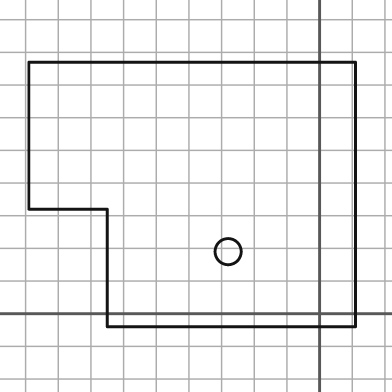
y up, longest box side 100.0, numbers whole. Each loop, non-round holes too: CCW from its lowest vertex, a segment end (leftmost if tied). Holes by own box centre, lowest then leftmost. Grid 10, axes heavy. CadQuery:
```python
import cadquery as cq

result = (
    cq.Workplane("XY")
    .moveTo(-65.0, -4.0)
    .lineTo(11.0, -4.0)
    .lineTo(11.0, 77.0)
    .lineTo(-89.0, 77.0)
    .lineTo(-89.0, 32.0)
    .lineTo(-65.0, 32.0)
    .close()
    .moveTo(-28.0, 19.0)
    .circle(4.0)
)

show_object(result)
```